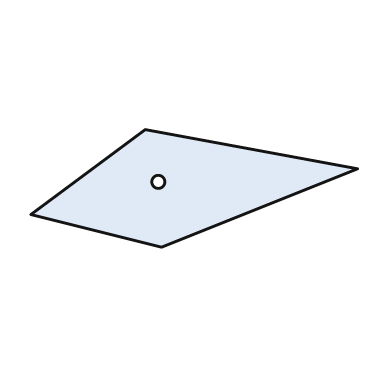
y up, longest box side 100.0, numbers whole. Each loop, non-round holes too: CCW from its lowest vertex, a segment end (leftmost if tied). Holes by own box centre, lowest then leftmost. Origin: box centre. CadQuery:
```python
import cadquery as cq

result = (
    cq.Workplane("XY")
    .moveTo(-10.0, -18.0)
    .lineTo(50.0, 6.0)
    .lineTo(-15.0, 18.0)
    .lineTo(-50.0, -8.0)
    .close()
    .moveTo(-11.0, 2.0)
    .circle(2.0)
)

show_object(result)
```